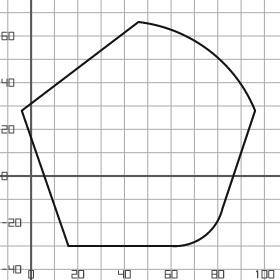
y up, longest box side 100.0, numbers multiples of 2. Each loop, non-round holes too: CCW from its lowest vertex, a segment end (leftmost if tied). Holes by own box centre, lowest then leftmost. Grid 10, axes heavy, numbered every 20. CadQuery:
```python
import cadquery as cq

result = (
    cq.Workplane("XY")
    .moveTo(16.0, -30.0)
    .lineTo(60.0, -30.0)
    .threePointArc((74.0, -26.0), (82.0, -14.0))
    .lineTo(96.0, 28.0)
    .threePointArc((76.0, 54.0), (46.0, 66.0))
    .lineTo(-4.0, 28.0)
    .close()
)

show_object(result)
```